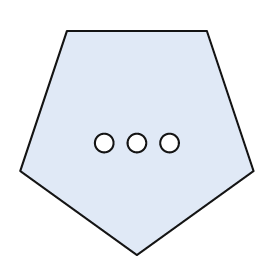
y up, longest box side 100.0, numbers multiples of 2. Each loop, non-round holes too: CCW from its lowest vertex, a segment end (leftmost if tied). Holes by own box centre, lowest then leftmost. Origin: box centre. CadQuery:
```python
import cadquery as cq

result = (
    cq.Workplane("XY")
    .moveTo(0.0, -48.0)
    .lineTo(50.0, -12.0)
    .lineTo(30.0, 48.0)
    .lineTo(-30.0, 48.0)
    .lineTo(-50.0, -12.0)
    .close()
    .moveTo(-14.0, 0.0)
    .circle(4.0)
    .moveTo(0.0, 0.0)
    .circle(4.0)
    .moveTo(14.0, 0.0)
    .circle(4.0)
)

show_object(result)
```